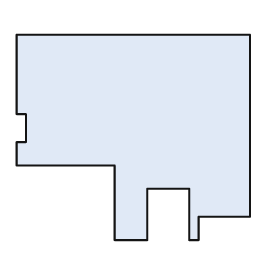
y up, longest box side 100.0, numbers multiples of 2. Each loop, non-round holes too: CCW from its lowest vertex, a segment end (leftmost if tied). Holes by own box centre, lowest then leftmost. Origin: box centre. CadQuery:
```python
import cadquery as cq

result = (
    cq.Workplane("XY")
    .moveTo(-8.0, -44.0)
    .lineTo(6.0, -44.0)
    .lineTo(6.0, -22.0)
    .lineTo(24.0, -22.0)
    .lineTo(24.0, -44.0)
    .lineTo(28.0, -44.0)
    .lineTo(28.0, -34.0)
    .lineTo(50.0, -34.0)
    .lineTo(50.0, 44.0)
    .lineTo(-50.0, 44.0)
    .lineTo(-50.0, 10.0)
    .lineTo(-46.0, 10.0)
    .lineTo(-46.0, -2.0)
    .lineTo(-50.0, -2.0)
    .lineTo(-50.0, -12.0)
    .lineTo(-8.0, -12.0)
    .close()
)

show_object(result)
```